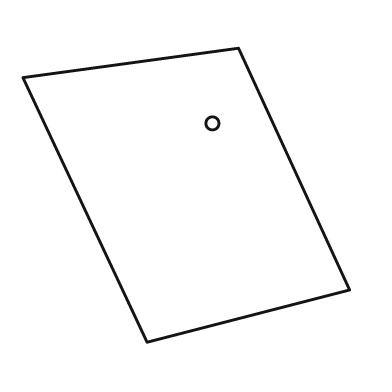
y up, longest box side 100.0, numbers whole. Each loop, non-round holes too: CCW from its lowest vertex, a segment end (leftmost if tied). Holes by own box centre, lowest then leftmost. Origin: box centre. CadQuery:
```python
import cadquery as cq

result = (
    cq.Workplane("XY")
    .moveTo(-12.0, -45.0)
    .lineTo(50.0, -29.0)
    .lineTo(16.0, 45.0)
    .lineTo(-50.0, 36.0)
    .close()
    .moveTo(8.0, 22.0)
    .circle(2.0)
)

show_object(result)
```